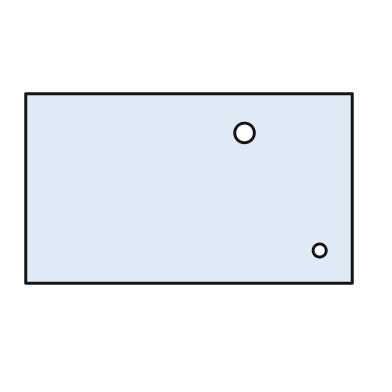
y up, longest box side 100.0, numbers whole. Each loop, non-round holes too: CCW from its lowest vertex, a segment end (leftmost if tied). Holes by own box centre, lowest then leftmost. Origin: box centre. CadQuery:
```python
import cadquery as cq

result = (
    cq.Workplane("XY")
    .moveTo(-50.0, -29.0)
    .lineTo(50.0, -29.0)
    .lineTo(50.0, 29.0)
    .lineTo(-50.0, 29.0)
    .close()
    .moveTo(40.0, -19.0)
    .circle(2.0)
    .moveTo(17.0, 17.0)
    .circle(3.0)
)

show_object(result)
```